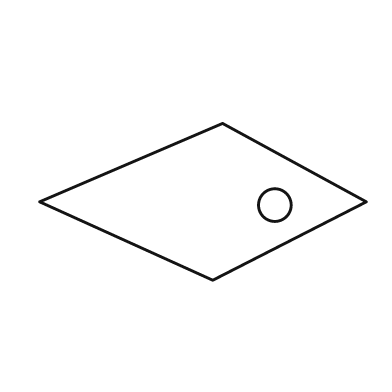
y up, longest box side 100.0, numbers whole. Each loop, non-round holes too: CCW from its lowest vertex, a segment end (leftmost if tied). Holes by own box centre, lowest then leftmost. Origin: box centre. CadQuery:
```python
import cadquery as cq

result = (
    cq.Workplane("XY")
    .moveTo(3.0, -24.0)
    .lineTo(50.0, 0.0)
    .lineTo(6.0, 24.0)
    .lineTo(-50.0, 0.0)
    .close()
    .moveTo(22.0, -1.0)
    .circle(5.0)
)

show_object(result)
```